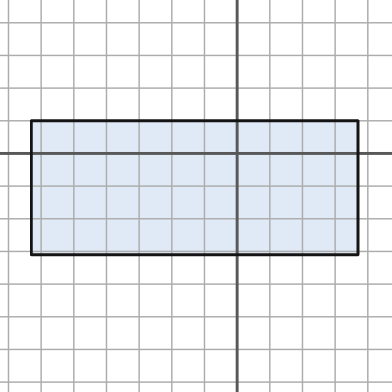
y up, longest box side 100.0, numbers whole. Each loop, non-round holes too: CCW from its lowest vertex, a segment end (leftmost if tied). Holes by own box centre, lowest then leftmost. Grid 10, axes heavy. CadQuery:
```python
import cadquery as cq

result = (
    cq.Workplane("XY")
    .moveTo(-63.0, -31.0)
    .lineTo(37.0, -31.0)
    .lineTo(37.0, 10.0)
    .lineTo(-63.0, 10.0)
    .close()
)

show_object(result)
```